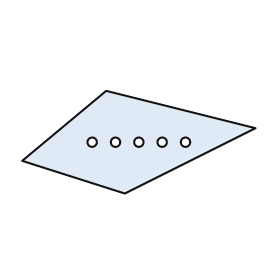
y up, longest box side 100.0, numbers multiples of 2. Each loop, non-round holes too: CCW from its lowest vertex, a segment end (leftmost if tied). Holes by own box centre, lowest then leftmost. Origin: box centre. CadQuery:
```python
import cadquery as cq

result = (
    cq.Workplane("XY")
    .moveTo(-6.0, -22.0)
    .lineTo(50.0, 6.0)
    .lineTo(-14.0, 22.0)
    .lineTo(-50.0, -8.0)
    .close()
    .moveTo(-20.0, 0.0)
    .circle(2.0)
    .moveTo(-10.0, 0.0)
    .circle(2.0)
    .moveTo(0.0, 0.0)
    .circle(2.0)
    .moveTo(10.0, 0.0)
    .circle(2.0)
    .moveTo(20.0, 0.0)
    .circle(2.0)
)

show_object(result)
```